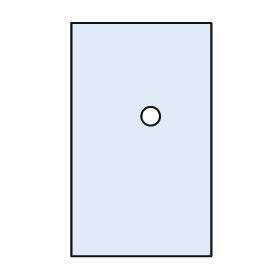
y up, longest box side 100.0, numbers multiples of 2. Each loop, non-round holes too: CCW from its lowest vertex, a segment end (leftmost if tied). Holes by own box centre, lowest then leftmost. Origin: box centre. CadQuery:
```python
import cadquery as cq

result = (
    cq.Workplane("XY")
    .moveTo(-30.0, -50.0)
    .lineTo(30.0, -50.0)
    .lineTo(30.0, 50.0)
    .lineTo(-30.0, 50.0)
    .close()
    .moveTo(4.0, 10.0)
    .circle(4.0)
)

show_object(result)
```